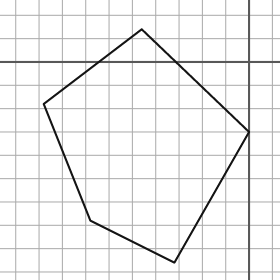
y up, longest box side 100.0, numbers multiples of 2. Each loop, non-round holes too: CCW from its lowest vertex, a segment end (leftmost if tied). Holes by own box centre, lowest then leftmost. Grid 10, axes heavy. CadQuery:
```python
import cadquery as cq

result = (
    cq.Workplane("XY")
    .moveTo(-32.0, -86.0)
    .lineTo(0.0, -30.0)
    .lineTo(-46.0, 14.0)
    .lineTo(-88.0, -18.0)
    .lineTo(-68.0, -68.0)
    .close()
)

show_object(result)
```